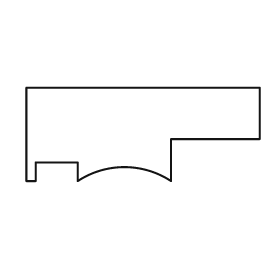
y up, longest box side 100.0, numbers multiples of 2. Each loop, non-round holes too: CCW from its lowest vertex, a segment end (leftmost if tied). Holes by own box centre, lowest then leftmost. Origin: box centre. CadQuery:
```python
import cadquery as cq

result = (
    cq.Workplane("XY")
    .moveTo(-50.0, -20.0)
    .lineTo(-46.0, -20.0)
    .lineTo(-46.0, -12.0)
    .lineTo(-28.0, -12.0)
    .lineTo(-28.0, -20.0)
    .threePointArc((-8.0, -14.0), (12.0, -20.0))
    .lineTo(12.0, -2.0)
    .lineTo(50.0, -2.0)
    .lineTo(50.0, 20.0)
    .lineTo(-50.0, 20.0)
    .close()
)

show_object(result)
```